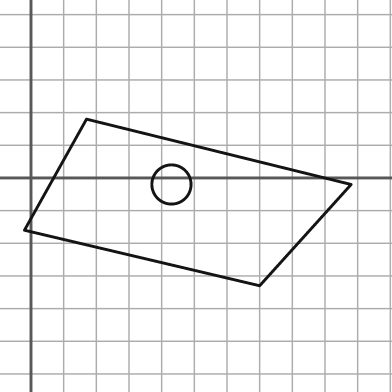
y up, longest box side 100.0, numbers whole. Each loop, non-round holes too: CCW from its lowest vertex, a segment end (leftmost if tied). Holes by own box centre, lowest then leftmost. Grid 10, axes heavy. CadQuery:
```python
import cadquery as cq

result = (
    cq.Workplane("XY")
    .moveTo(70.0, -33.0)
    .lineTo(98.0, -2.0)
    .lineTo(17.0, 18.0)
    .lineTo(-2.0, -16.0)
    .close()
    .moveTo(43.0, -2.0)
    .circle(6.0)
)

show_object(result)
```